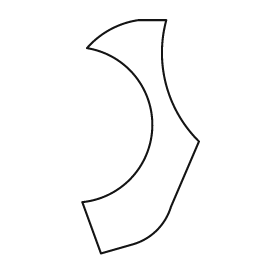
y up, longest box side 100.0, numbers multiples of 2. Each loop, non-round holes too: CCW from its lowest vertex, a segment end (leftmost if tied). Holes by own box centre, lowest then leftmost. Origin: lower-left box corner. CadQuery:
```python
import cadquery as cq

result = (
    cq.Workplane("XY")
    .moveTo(8.0, 0.0)
    .lineTo(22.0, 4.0)
    .threePointArc((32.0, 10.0), (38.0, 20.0))
    .lineTo(50.0, 48.0)
    .threePointArc((36.0, 72.0), (36.0, 100.0))
    .lineTo(24.0, 100.0)
    .threePointArc((12.0, 96.0), (2.0, 88.0))
    .threePointArc((30.0, 54.0), (0.0, 22.0))
    .close()
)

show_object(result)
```